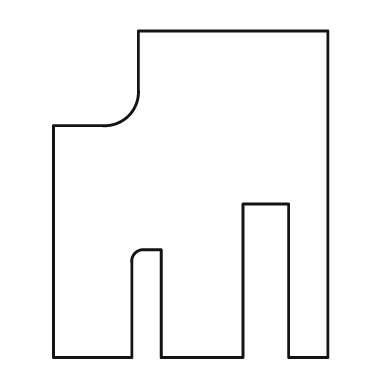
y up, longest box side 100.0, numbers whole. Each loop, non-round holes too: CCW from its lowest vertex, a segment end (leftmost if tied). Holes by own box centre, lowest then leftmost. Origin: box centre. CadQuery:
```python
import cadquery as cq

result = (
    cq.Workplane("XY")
    .moveTo(-42.0, -50.0)
    .lineTo(-18.0, -50.0)
    .lineTo(-18.0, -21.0)
    .threePointArc((-17.0, -18.0), (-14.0, -17.0))
    .lineTo(-9.0, -17.0)
    .lineTo(-9.0, -50.0)
    .lineTo(16.0, -50.0)
    .lineTo(16.0, -3.0)
    .lineTo(30.0, -3.0)
    .lineTo(30.0, -50.0)
    .lineTo(42.0, -50.0)
    .lineTo(42.0, 50.0)
    .lineTo(-16.0, 50.0)
    .lineTo(-16.0, 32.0)
    .threePointArc((-19.0, 24.0), (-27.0, 21.0))
    .lineTo(-42.0, 21.0)
    .close()
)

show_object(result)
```